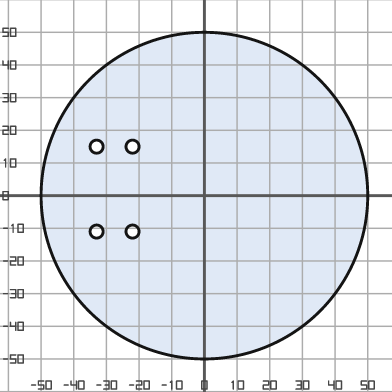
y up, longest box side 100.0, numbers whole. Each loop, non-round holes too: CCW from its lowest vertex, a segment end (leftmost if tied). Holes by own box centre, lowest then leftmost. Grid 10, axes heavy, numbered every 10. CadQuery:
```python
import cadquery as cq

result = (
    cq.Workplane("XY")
    .moveTo(0.0, 0.0)
    .circle(50.0)
    .moveTo(-33.0, -11.0)
    .circle(2.0)
    .moveTo(-22.0, -11.0)
    .circle(2.0)
    .moveTo(-33.0, 15.0)
    .circle(2.0)
    .moveTo(-22.0, 15.0)
    .circle(2.0)
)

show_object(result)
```